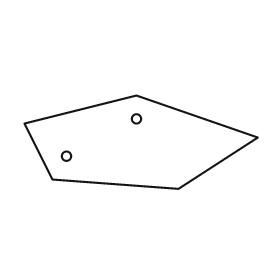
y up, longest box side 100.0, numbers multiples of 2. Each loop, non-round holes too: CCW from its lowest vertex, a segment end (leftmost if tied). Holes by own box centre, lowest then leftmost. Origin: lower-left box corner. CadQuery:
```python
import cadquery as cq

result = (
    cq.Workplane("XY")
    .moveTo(66.0, 0.0)
    .lineTo(100.0, 22.0)
    .lineTo(48.0, 40.0)
    .lineTo(0.0, 28.0)
    .lineTo(12.0, 4.0)
    .close()
    .moveTo(18.0, 14.0)
    .circle(2.0)
    .moveTo(48.0, 30.0)
    .circle(2.0)
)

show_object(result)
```